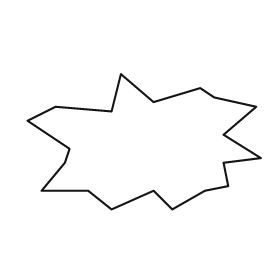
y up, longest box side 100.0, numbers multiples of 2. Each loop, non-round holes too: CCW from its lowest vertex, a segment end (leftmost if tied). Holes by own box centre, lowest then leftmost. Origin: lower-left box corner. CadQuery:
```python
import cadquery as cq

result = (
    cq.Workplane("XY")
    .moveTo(36.0, 0.0)
    .lineTo(54.0, 8.0)
    .lineTo(62.0, 0.0)
    .lineTo(76.0, 8.0)
    .lineTo(86.0, 10.0)
    .lineTo(84.0, 20.0)
    .lineTo(100.0, 22.0)
    .lineTo(84.0, 32.0)
    .lineTo(98.0, 44.0)
    .lineTo(80.0, 48.0)
    .lineTo(74.0, 52.0)
    .lineTo(54.0, 46.0)
    .lineTo(40.0, 58.0)
    .lineTo(36.0, 42.0)
    .lineTo(12.0, 44.0)
    .lineTo(0.0, 38.0)
    .lineTo(18.0, 26.0)
    .lineTo(16.0, 20.0)
    .lineTo(6.0, 8.0)
    .lineTo(26.0, 8.0)
    .close()
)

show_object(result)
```